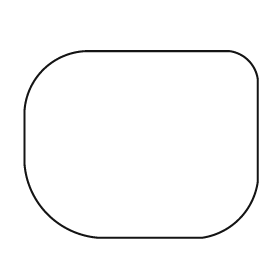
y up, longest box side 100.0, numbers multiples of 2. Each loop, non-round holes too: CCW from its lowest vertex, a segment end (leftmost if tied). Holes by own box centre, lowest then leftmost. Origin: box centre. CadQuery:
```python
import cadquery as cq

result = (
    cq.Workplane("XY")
    .moveTo(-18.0, -40.0)
    .lineTo(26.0, -40.0)
    .threePointArc((42.0, -32.0), (50.0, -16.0))
    .lineTo(50.0, 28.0)
    .threePointArc((46.0, 36.0), (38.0, 40.0))
    .lineTo(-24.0, 40.0)
    .threePointArc((-42.0, 32.0), (-50.0, 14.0))
    .lineTo(-50.0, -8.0)
    .threePointArc((-40.0, -30.0), (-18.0, -40.0))
    .close()
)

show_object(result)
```